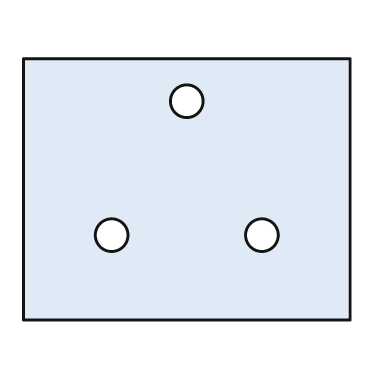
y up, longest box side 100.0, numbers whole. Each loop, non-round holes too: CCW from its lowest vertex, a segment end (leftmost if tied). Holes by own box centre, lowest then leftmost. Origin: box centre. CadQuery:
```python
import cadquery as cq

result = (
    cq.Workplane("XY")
    .moveTo(-50.0, -40.0)
    .lineTo(50.0, -40.0)
    .lineTo(50.0, 40.0)
    .lineTo(-50.0, 40.0)
    .close()
    .moveTo(-23.0, -14.0)
    .circle(5.0)
    .moveTo(23.0, -14.0)
    .circle(5.0)
    .moveTo(0.0, 27.0)
    .circle(5.0)
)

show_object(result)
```